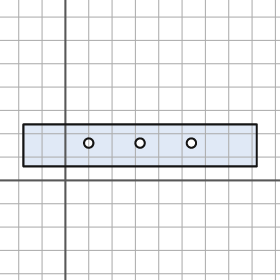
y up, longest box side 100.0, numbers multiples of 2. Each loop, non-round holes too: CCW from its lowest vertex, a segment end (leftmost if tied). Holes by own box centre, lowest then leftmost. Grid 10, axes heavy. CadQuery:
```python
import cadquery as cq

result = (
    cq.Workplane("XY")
    .moveTo(-18.0, 6.0)
    .lineTo(82.0, 6.0)
    .lineTo(82.0, 24.0)
    .lineTo(-18.0, 24.0)
    .close()
    .moveTo(10.0, 16.0)
    .circle(2.0)
    .moveTo(32.0, 16.0)
    .circle(2.0)
    .moveTo(54.0, 16.0)
    .circle(2.0)
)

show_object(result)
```